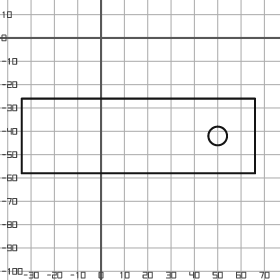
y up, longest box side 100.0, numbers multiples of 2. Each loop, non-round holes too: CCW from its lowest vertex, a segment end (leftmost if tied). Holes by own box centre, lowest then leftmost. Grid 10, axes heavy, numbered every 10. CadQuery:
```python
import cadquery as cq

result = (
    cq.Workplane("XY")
    .moveTo(-34.0, -58.0)
    .lineTo(66.0, -58.0)
    .lineTo(66.0, -26.0)
    .lineTo(-34.0, -26.0)
    .close()
    .moveTo(50.0, -42.0)
    .circle(4.0)
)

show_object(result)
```